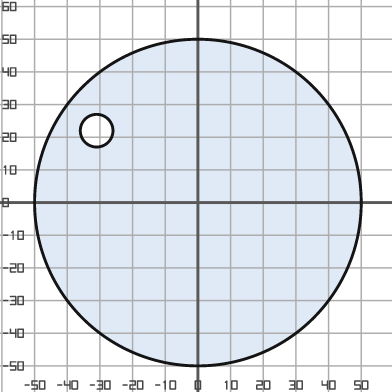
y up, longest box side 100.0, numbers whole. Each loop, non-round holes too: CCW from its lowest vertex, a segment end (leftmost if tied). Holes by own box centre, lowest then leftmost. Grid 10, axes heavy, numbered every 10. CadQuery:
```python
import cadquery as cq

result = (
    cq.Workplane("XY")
    .moveTo(0.0, 0.0)
    .circle(50.0)
    .moveTo(-31.0, 22.0)
    .circle(5.0)
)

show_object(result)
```